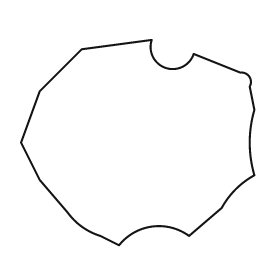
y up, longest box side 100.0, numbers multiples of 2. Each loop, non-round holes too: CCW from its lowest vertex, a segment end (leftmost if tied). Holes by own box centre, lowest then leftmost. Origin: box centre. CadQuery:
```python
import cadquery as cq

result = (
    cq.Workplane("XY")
    .moveTo(-8.0, -44.0)
    .threePointArc((6.0, -36.0), (22.0, -40.0))
    .lineTo(36.0, -28.0)
    .threePointArc((42.0, -20.0), (50.0, -14.0))
    .threePointArc((48.0, 0.0), (50.0, 14.0))
    .lineTo(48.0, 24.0)
    .threePointArc((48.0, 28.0), (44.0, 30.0))
    .lineTo(24.0, 38.0)
    .threePointArc((12.0, 32.0), (6.0, 44.0))
    .lineTo(-24.0, 40.0)
    .lineTo(-42.0, 22.0)
    .lineTo(-50.0, 0.0)
    .lineTo(-42.0, -16.0)
    .lineTo(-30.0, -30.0)
    .threePointArc((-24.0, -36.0), (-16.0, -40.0))
    .close()
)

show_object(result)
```